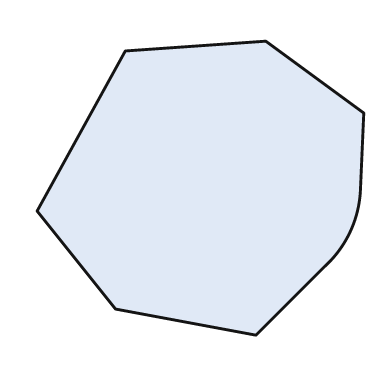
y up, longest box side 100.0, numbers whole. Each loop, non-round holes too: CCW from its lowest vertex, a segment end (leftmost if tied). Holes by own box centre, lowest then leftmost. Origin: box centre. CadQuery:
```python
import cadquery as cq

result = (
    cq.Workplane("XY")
    .moveTo(17.0, -45.0)
    .lineTo(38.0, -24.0)
    .threePointArc((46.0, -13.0), (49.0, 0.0))
    .lineTo(50.0, 23.0)
    .lineTo(20.0, 45.0)
    .lineTo(-23.0, 42.0)
    .lineTo(-50.0, -7.0)
    .lineTo(-26.0, -37.0)
    .close()
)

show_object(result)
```